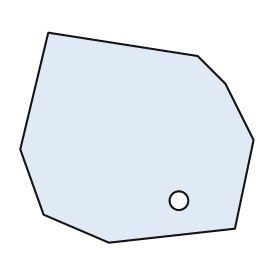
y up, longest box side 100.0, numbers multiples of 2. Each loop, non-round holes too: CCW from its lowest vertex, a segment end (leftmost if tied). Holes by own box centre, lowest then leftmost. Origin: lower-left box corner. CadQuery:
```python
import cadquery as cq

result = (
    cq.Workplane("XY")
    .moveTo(38.0, 0.0)
    .lineTo(92.0, 6.0)
    .lineTo(100.0, 44.0)
    .lineTo(88.0, 68.0)
    .lineTo(76.0, 80.0)
    .lineTo(12.0, 90.0)
    .lineTo(0.0, 40.0)
    .lineTo(10.0, 12.0)
    .close()
    .moveTo(68.0, 18.0)
    .circle(4.0)
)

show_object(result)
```